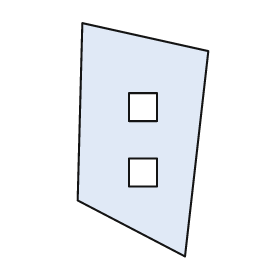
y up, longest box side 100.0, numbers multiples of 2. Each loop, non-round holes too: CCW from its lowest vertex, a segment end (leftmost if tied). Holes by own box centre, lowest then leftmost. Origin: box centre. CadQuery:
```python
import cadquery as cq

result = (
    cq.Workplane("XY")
    .moveTo(18.0, -50.0)
    .lineTo(28.0, 38.0)
    .lineTo(-26.0, 50.0)
    .lineTo(-28.0, -26.0)
    .close()
    .moveTo(-6.0, -20.0)
    .lineTo(6.0, -20.0)
    .lineTo(6.0, -8.0)
    .lineTo(-6.0, -8.0)
    .close()
    .moveTo(-6.0, 8.0)
    .lineTo(6.0, 8.0)
    .lineTo(6.0, 20.0)
    .lineTo(-6.0, 20.0)
    .close()
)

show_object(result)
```